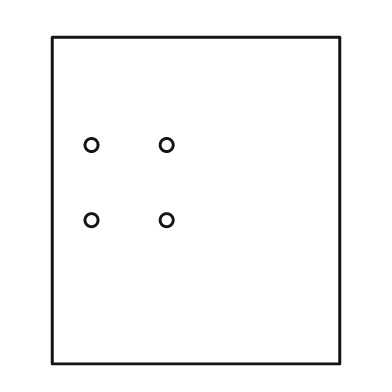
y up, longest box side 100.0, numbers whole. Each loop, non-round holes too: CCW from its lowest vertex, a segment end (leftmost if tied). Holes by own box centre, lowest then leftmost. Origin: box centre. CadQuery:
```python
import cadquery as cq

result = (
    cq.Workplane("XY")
    .moveTo(-44.0, -50.0)
    .lineTo(44.0, -50.0)
    .lineTo(44.0, 50.0)
    .lineTo(-44.0, 50.0)
    .close()
    .moveTo(-32.0, -6.0)
    .circle(2.0)
    .moveTo(-9.0, -6.0)
    .circle(2.0)
    .moveTo(-32.0, 17.0)
    .circle(2.0)
    .moveTo(-9.0, 17.0)
    .circle(2.0)
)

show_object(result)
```